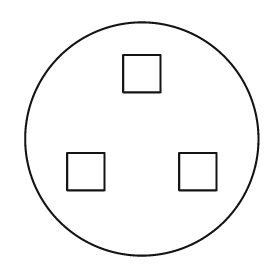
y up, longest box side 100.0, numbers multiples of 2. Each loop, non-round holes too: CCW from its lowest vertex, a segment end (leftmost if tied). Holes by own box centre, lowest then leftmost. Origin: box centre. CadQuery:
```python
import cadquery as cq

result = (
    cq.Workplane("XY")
    .moveTo(0.0, 0.0)
    .circle(50.0)
    .moveTo(-32.0, -22.0)
    .lineTo(-16.0, -22.0)
    .lineTo(-16.0, -6.0)
    .lineTo(-32.0, -6.0)
    .close()
    .moveTo(16.0, -22.0)
    .lineTo(32.0, -22.0)
    .lineTo(32.0, -6.0)
    .lineTo(16.0, -6.0)
    .close()
    .moveTo(-8.0, 20.0)
    .lineTo(8.0, 20.0)
    .lineTo(8.0, 36.0)
    .lineTo(-8.0, 36.0)
    .close()
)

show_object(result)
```